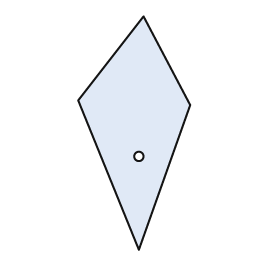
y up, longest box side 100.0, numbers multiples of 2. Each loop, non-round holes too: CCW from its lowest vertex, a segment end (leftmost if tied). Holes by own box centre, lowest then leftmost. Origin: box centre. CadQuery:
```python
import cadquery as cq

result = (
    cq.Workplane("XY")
    .moveTo(2.0, -50.0)
    .lineTo(24.0, 12.0)
    .lineTo(4.0, 50.0)
    .lineTo(-24.0, 14.0)
    .close()
    .moveTo(2.0, -10.0)
    .circle(2.0)
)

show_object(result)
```